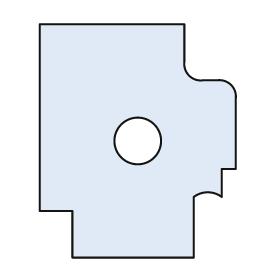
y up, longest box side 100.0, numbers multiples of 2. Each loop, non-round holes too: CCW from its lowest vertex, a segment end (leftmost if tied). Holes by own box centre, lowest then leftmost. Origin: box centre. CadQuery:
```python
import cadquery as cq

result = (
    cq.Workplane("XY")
    .moveTo(-28.0, -50.0)
    .lineTo(24.0, -50.0)
    .lineTo(24.0, -24.0)
    .threePointArc((30.0, -22.0), (36.0, -24.0))
    .lineTo(36.0, -12.0)
    .lineTo(42.0, -12.0)
    .lineTo(42.0, 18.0)
    .threePointArc((40.0, 24.0), (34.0, 26.0))
    .lineTo(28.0, 26.0)
    .threePointArc((22.0, 28.0), (20.0, 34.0))
    .lineTo(20.0, 50.0)
    .lineTo(-42.0, 50.0)
    .lineTo(-42.0, -30.0)
    .lineTo(-28.0, -30.0)
    .close()
    .moveTo(0.0, 0.0)
    .circle(10.0)
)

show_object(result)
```